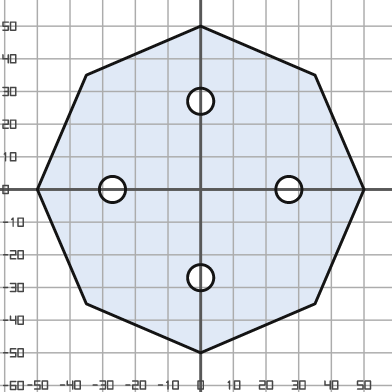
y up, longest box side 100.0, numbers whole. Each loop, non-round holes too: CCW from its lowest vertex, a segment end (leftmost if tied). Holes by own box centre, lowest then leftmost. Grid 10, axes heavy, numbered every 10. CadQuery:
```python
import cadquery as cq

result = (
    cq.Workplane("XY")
    .moveTo(0.0, -50.0)
    .lineTo(35.0, -35.0)
    .lineTo(50.0, 0.0)
    .lineTo(35.0, 35.0)
    .lineTo(0.0, 50.0)
    .lineTo(-35.0, 35.0)
    .lineTo(-50.0, 0.0)
    .lineTo(-35.0, -35.0)
    .close()
    .moveTo(0.0, -27.0)
    .circle(4.0)
    .moveTo(-27.0, 0.0)
    .circle(4.0)
    .moveTo(27.0, 0.0)
    .circle(4.0)
    .moveTo(0.0, 27.0)
    .circle(4.0)
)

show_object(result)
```